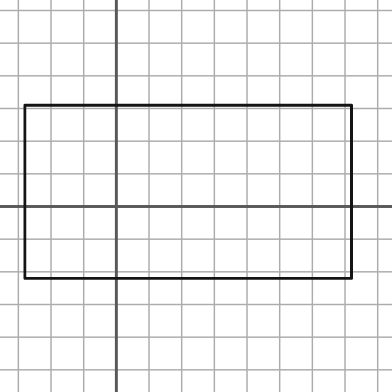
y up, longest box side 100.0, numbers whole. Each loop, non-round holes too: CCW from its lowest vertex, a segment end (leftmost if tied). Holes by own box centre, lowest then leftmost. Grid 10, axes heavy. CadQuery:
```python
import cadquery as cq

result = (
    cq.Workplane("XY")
    .moveTo(-28.0, -22.0)
    .lineTo(72.0, -22.0)
    .lineTo(72.0, 31.0)
    .lineTo(-28.0, 31.0)
    .close()
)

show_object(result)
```